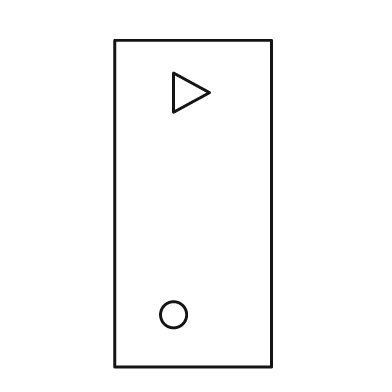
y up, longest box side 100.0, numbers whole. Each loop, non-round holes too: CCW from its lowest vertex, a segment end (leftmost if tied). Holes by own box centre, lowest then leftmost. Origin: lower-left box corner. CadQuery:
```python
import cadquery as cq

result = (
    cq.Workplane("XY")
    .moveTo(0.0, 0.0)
    .lineTo(48.0, 0.0)
    .lineTo(48.0, 100.0)
    .lineTo(0.0, 100.0)
    .close()
    .moveTo(18.0, 16.0)
    .circle(4.0)
    .moveTo(18.0, 78.0)
    .lineTo(29.0, 84.0)
    .lineTo(18.0, 90.0)
    .close()
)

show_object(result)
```